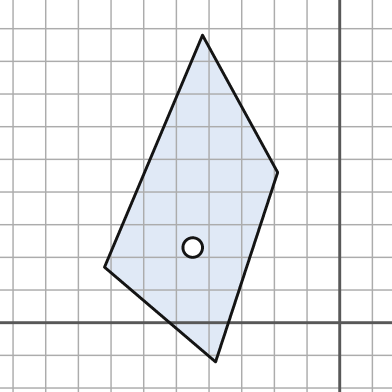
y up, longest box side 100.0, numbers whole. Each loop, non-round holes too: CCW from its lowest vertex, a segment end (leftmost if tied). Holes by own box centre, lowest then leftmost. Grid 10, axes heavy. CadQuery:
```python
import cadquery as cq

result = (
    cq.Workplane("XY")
    .moveTo(-38.0, -12.0)
    .lineTo(-19.0, 46.0)
    .lineTo(-42.0, 88.0)
    .lineTo(-72.0, 17.0)
    .close()
    .moveTo(-45.0, 23.0)
    .circle(3.0)
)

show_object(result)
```